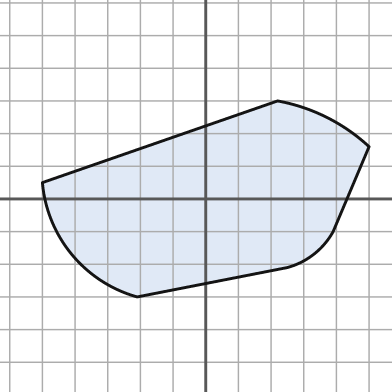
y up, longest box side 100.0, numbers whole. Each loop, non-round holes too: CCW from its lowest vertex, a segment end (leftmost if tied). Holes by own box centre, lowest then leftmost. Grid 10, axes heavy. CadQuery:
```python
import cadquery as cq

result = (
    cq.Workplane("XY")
    .moveTo(-21.0, -30.0)
    .lineTo(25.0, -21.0)
    .threePointArc((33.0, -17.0), (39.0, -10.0))
    .lineTo(50.0, 16.0)
    .threePointArc((37.0, 25.0), (22.0, 30.0))
    .lineTo(-50.0, 5.0)
    .threePointArc((-41.0, -17.0), (-21.0, -30.0))
    .close()
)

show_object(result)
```